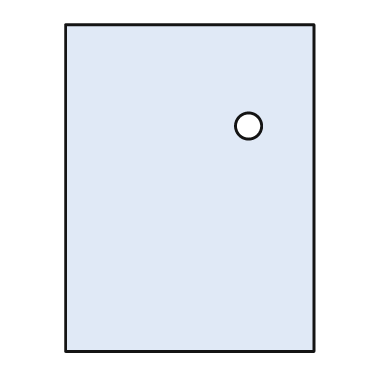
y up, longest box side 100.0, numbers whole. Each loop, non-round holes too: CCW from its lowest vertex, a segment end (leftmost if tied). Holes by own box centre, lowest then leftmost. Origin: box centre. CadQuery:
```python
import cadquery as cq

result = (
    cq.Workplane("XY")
    .moveTo(-38.0, -50.0)
    .lineTo(38.0, -50.0)
    .lineTo(38.0, 50.0)
    .lineTo(-38.0, 50.0)
    .close()
    .moveTo(18.0, 19.0)
    .circle(4.0)
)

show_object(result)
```